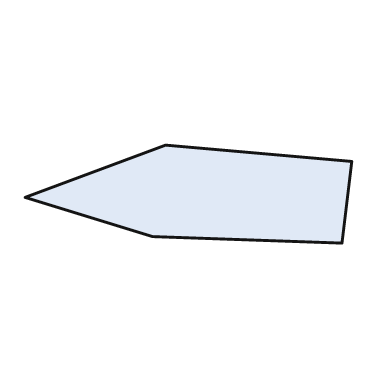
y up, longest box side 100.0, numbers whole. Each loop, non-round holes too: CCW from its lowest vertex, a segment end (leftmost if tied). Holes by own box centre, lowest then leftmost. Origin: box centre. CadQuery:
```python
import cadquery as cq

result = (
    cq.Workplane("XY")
    .moveTo(47.0, -15.0)
    .lineTo(50.0, 10.0)
    .lineTo(-7.0, 15.0)
    .lineTo(-50.0, -1.0)
    .lineTo(-11.0, -13.0)
    .close()
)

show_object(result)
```